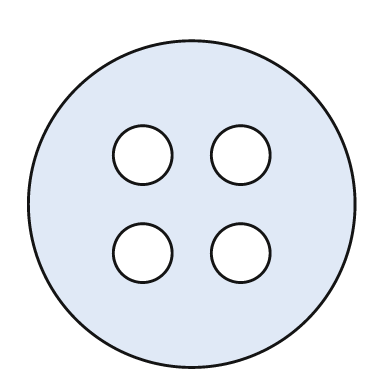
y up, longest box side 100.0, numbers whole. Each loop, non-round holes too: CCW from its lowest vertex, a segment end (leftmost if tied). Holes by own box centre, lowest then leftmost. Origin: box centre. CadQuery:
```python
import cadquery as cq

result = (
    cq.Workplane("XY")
    .moveTo(0.0, 0.0)
    .circle(50.0)
    .moveTo(-15.0, -15.0)
    .circle(9.0)
    .moveTo(15.0, -15.0)
    .circle(9.0)
    .moveTo(-15.0, 15.0)
    .circle(9.0)
    .moveTo(15.0, 15.0)
    .circle(9.0)
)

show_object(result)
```